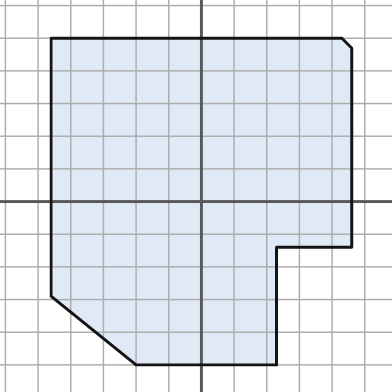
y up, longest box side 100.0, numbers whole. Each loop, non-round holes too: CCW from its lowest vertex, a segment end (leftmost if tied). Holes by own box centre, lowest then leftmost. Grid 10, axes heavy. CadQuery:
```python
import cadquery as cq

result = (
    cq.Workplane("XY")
    .moveTo(-20.0, -50.0)
    .lineTo(23.0, -50.0)
    .lineTo(23.0, -14.0)
    .lineTo(46.0, -14.0)
    .lineTo(46.0, 47.0)
    .lineTo(43.0, 50.0)
    .lineTo(-46.0, 50.0)
    .lineTo(-46.0, -29.0)
    .close()
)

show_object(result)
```